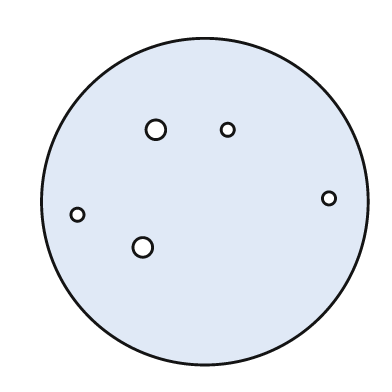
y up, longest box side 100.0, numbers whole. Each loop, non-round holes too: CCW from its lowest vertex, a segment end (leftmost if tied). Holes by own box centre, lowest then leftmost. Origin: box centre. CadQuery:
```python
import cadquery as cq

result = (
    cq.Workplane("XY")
    .moveTo(0.0, 0.0)
    .circle(50.0)
    .moveTo(-19.0, -14.0)
    .circle(3.0)
    .moveTo(-39.0, -4.0)
    .circle(2.0)
    .moveTo(38.0, 1.0)
    .circle(2.0)
    .moveTo(-15.0, 22.0)
    .circle(3.0)
    .moveTo(7.0, 22.0)
    .circle(2.0)
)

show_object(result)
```